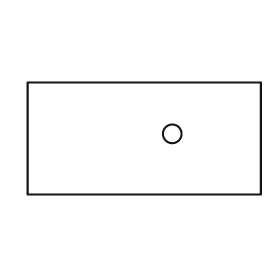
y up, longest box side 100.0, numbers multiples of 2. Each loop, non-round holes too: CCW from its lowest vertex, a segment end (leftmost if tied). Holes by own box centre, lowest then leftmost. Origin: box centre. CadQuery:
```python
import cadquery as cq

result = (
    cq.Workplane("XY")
    .moveTo(-50.0, -24.0)
    .lineTo(50.0, -24.0)
    .lineTo(50.0, 24.0)
    .lineTo(-50.0, 24.0)
    .close()
    .moveTo(12.0, 2.0)
    .circle(4.0)
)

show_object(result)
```